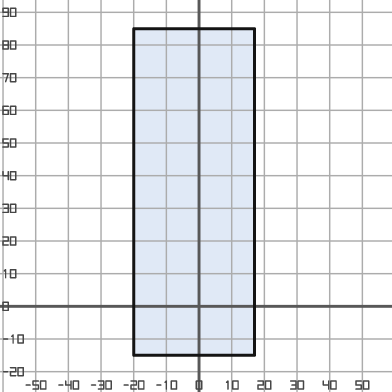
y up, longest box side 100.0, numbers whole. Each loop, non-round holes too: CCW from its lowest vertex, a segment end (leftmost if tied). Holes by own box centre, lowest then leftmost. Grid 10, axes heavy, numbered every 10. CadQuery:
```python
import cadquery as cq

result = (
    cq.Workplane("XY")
    .moveTo(-20.0, -15.0)
    .lineTo(17.0, -15.0)
    .lineTo(17.0, 85.0)
    .lineTo(-20.0, 85.0)
    .close()
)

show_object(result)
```